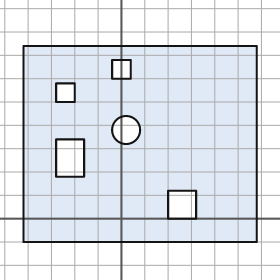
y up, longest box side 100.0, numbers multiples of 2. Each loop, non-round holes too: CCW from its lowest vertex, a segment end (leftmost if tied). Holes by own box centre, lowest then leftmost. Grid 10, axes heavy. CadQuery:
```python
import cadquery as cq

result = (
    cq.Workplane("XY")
    .moveTo(-42.0, -10.0)
    .lineTo(58.0, -10.0)
    .lineTo(58.0, 74.0)
    .lineTo(-42.0, 74.0)
    .close()
    .moveTo(20.0, 0.0)
    .lineTo(32.0, 0.0)
    .lineTo(32.0, 12.0)
    .lineTo(20.0, 12.0)
    .close()
    .moveTo(-28.0, 18.0)
    .lineTo(-16.0, 18.0)
    .lineTo(-16.0, 34.0)
    .lineTo(-28.0, 34.0)
    .close()
    .moveTo(2.0, 38.0)
    .circle(6.0)
    .moveTo(-28.0, 50.0)
    .lineTo(-20.0, 50.0)
    .lineTo(-20.0, 58.0)
    .lineTo(-28.0, 58.0)
    .close()
    .moveTo(-4.0, 60.0)
    .lineTo(4.0, 60.0)
    .lineTo(4.0, 68.0)
    .lineTo(-4.0, 68.0)
    .close()
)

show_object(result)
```